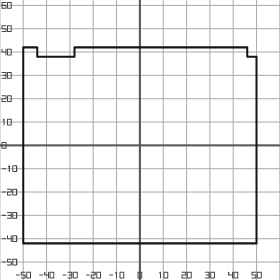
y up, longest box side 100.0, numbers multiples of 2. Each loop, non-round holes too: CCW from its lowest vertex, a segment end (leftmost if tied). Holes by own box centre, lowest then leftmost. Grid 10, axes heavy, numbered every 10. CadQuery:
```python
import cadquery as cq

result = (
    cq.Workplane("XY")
    .moveTo(-50.0, -42.0)
    .lineTo(50.0, -42.0)
    .lineTo(50.0, 38.0)
    .lineTo(46.0, 38.0)
    .lineTo(46.0, 42.0)
    .lineTo(-28.0, 42.0)
    .lineTo(-28.0, 38.0)
    .lineTo(-44.0, 38.0)
    .lineTo(-44.0, 42.0)
    .lineTo(-50.0, 42.0)
    .close()
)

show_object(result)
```